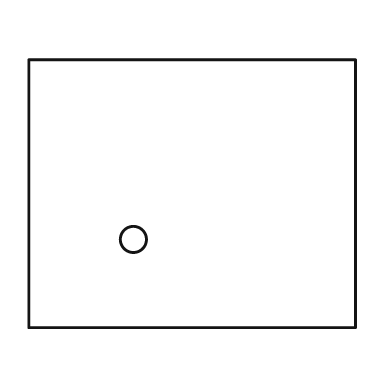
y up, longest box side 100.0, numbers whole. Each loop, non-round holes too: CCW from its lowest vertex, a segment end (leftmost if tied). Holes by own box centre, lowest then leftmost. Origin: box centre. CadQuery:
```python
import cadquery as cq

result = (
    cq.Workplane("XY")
    .moveTo(-50.0, -41.0)
    .lineTo(50.0, -41.0)
    .lineTo(50.0, 41.0)
    .lineTo(-50.0, 41.0)
    .close()
    .moveTo(-18.0, -14.0)
    .circle(4.0)
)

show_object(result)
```